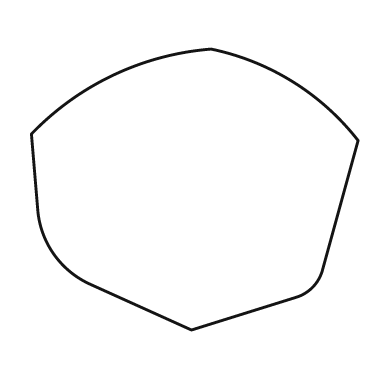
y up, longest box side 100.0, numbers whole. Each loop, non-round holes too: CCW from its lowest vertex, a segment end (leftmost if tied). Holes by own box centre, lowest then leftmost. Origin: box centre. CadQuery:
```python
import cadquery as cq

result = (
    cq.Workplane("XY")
    .moveTo(-1.0, -43.0)
    .lineTo(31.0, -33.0)
    .threePointArc((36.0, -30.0), (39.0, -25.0))
    .lineTo(50.0, 15.0)
    .threePointArc((30.0, 33.0), (5.0, 43.0))
    .threePointArc((-25.0, 35.0), (-50.0, 17.0))
    .lineTo(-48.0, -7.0)
    .threePointArc((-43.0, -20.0), (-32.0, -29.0))
    .close()
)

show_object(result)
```